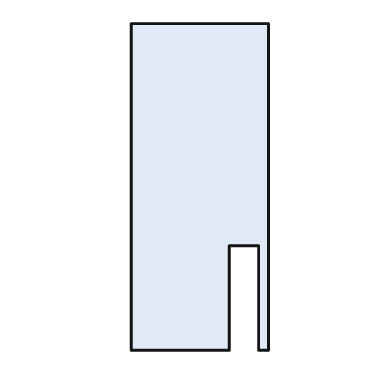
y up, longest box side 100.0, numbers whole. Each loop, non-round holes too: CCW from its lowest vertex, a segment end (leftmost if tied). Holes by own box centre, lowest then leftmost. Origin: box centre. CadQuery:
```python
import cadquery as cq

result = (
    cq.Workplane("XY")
    .moveTo(-21.0, -50.0)
    .lineTo(9.0, -50.0)
    .lineTo(9.0, -18.0)
    .lineTo(18.0, -18.0)
    .lineTo(18.0, -50.0)
    .lineTo(21.0, -50.0)
    .lineTo(21.0, 50.0)
    .lineTo(-21.0, 50.0)
    .close()
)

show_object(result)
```